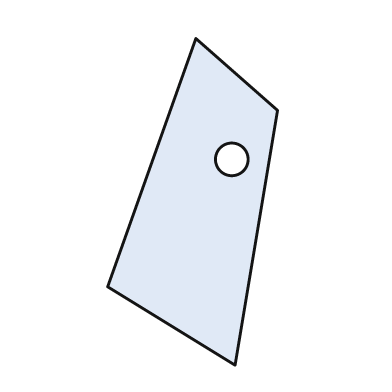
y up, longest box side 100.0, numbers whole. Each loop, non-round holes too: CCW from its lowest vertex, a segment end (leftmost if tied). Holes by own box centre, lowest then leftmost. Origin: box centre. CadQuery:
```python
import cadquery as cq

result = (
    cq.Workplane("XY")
    .moveTo(13.0, -50.0)
    .lineTo(26.0, 28.0)
    .lineTo(1.0, 50.0)
    .lineTo(-26.0, -26.0)
    .close()
    .moveTo(12.0, 13.0)
    .circle(5.0)
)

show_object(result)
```